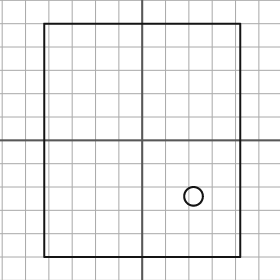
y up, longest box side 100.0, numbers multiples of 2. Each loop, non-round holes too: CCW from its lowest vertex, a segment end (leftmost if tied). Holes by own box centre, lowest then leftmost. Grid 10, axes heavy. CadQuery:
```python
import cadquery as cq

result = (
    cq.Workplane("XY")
    .moveTo(-42.0, -50.0)
    .lineTo(42.0, -50.0)
    .lineTo(42.0, 50.0)
    .lineTo(-42.0, 50.0)
    .close()
    .moveTo(22.0, -24.0)
    .circle(4.0)
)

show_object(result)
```